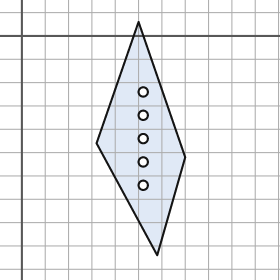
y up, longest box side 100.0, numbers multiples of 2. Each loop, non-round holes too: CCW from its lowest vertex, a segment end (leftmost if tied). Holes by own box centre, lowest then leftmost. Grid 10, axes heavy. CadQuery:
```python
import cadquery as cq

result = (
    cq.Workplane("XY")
    .moveTo(58.0, -94.0)
    .lineTo(70.0, -52.0)
    .lineTo(50.0, 6.0)
    .lineTo(32.0, -46.0)
    .close()
    .moveTo(52.0, -64.0)
    .circle(2.0)
    .moveTo(52.0, -54.0)
    .circle(2.0)
    .moveTo(52.0, -44.0)
    .circle(2.0)
    .moveTo(52.0, -34.0)
    .circle(2.0)
    .moveTo(52.0, -24.0)
    .circle(2.0)
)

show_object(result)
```